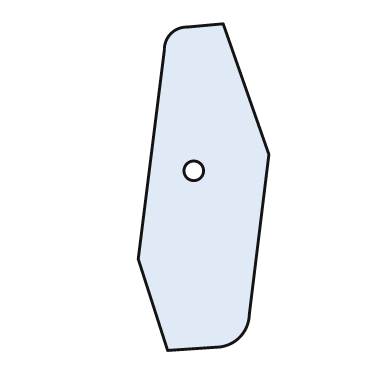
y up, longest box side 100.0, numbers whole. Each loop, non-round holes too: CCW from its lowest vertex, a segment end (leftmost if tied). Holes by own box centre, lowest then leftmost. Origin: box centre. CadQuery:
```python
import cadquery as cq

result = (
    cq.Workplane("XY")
    .moveTo(-11.0, -50.0)
    .lineTo(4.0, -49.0)
    .threePointArc((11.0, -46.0), (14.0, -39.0))
    .lineTo(20.0, 10.0)
    .lineTo(6.0, 50.0)
    .lineTo(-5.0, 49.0)
    .threePointArc((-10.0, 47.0), (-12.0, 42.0))
    .lineTo(-20.0, -22.0)
    .close()
    .moveTo(-3.0, 5.0)
    .circle(3.0)
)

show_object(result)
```